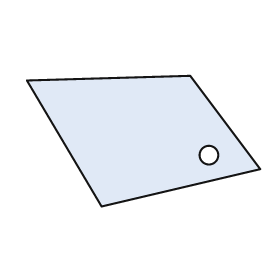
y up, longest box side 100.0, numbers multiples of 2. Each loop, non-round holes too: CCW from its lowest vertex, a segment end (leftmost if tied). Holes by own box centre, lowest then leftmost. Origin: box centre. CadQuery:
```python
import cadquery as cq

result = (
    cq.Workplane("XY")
    .moveTo(-18.0, -28.0)
    .lineTo(50.0, -12.0)
    .lineTo(20.0, 28.0)
    .lineTo(-50.0, 26.0)
    .close()
    .moveTo(28.0, -6.0)
    .circle(4.0)
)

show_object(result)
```